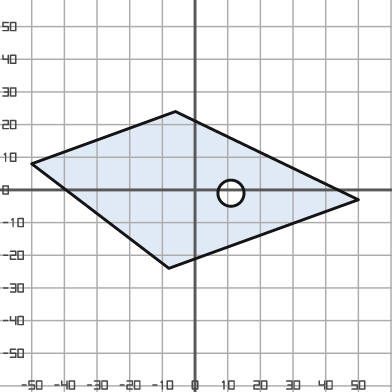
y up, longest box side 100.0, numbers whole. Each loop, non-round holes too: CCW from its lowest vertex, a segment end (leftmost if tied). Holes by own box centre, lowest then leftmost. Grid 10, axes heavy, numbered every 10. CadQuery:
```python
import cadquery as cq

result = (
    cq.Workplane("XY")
    .moveTo(-8.0, -24.0)
    .lineTo(50.0, -3.0)
    .lineTo(-6.0, 24.0)
    .lineTo(-50.0, 8.0)
    .close()
    .moveTo(11.0, -1.0)
    .circle(4.0)
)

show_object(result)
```